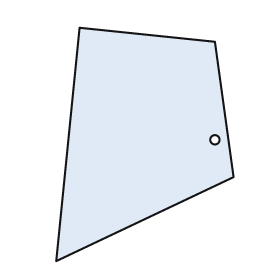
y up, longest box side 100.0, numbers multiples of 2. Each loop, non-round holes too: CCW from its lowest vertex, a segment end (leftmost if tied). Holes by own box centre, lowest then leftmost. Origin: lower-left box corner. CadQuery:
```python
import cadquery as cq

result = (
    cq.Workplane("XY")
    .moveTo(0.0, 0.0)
    .lineTo(76.0, 36.0)
    .lineTo(68.0, 94.0)
    .lineTo(10.0, 100.0)
    .close()
    .moveTo(68.0, 52.0)
    .circle(2.0)
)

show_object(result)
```